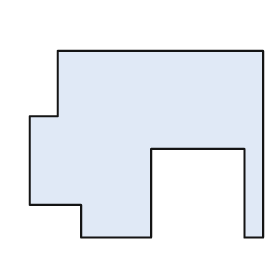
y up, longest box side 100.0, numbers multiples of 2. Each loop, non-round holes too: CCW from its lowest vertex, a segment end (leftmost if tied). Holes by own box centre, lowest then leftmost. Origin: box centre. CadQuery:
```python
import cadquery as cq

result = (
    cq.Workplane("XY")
    .moveTo(-28.0, -40.0)
    .lineTo(2.0, -40.0)
    .lineTo(2.0, -2.0)
    .lineTo(42.0, -2.0)
    .lineTo(42.0, -40.0)
    .lineTo(50.0, -40.0)
    .lineTo(50.0, 40.0)
    .lineTo(-38.0, 40.0)
    .lineTo(-38.0, 12.0)
    .lineTo(-50.0, 12.0)
    .lineTo(-50.0, -26.0)
    .lineTo(-28.0, -26.0)
    .close()
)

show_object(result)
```